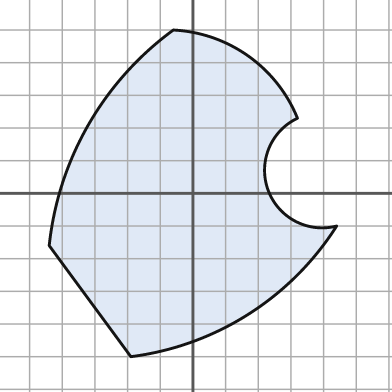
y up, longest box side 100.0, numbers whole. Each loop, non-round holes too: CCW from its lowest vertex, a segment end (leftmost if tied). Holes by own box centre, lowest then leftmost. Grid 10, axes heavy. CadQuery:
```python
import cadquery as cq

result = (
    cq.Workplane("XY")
    .moveTo(-19.0, -50.0)
    .threePointArc((17.0, -37.0), (44.0, -10.0))
    .threePointArc((23.0, 1.0), (32.0, 23.0))
    .threePointArc((17.0, 42.0), (-6.0, 50.0))
    .threePointArc((-32.0, 21.0), (-44.0, -16.0))
    .close()
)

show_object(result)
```